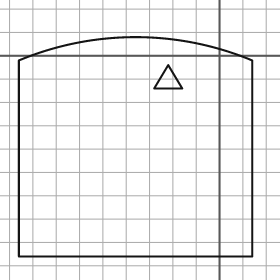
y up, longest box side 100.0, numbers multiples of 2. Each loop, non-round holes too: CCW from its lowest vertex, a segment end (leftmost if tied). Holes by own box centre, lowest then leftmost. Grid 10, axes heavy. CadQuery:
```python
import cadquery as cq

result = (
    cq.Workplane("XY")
    .moveTo(-86.0, -86.0)
    .lineTo(14.0, -86.0)
    .lineTo(14.0, -2.0)
    .threePointArc((-36.0, 8.0), (-86.0, -2.0))
    .close()
    .moveTo(-28.0, -14.0)
    .lineTo(-16.0, -14.0)
    .lineTo(-22.0, -4.0)
    .close()
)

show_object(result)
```